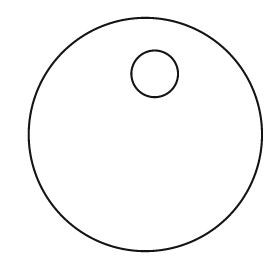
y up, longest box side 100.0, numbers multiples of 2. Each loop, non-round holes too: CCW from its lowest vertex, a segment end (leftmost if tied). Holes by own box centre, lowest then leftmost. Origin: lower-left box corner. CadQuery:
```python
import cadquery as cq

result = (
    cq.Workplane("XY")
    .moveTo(50.0, 50.0)
    .circle(50.0)
    .moveTo(54.0, 76.0)
    .circle(10.0)
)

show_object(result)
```